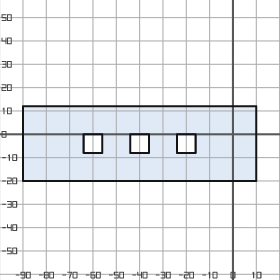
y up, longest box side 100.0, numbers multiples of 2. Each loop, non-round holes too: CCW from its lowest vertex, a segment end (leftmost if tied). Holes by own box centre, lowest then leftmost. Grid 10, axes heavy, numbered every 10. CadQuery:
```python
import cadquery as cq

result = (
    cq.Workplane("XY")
    .moveTo(-90.0, -20.0)
    .lineTo(10.0, -20.0)
    .lineTo(10.0, 12.0)
    .lineTo(-90.0, 12.0)
    .close()
    .moveTo(-64.0, -8.0)
    .lineTo(-56.0, -8.0)
    .lineTo(-56.0, 0.0)
    .lineTo(-64.0, 0.0)
    .close()
    .moveTo(-44.0, -8.0)
    .lineTo(-36.0, -8.0)
    .lineTo(-36.0, 0.0)
    .lineTo(-44.0, 0.0)
    .close()
    .moveTo(-24.0, -8.0)
    .lineTo(-16.0, -8.0)
    .lineTo(-16.0, 0.0)
    .lineTo(-24.0, 0.0)
    .close()
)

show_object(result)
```